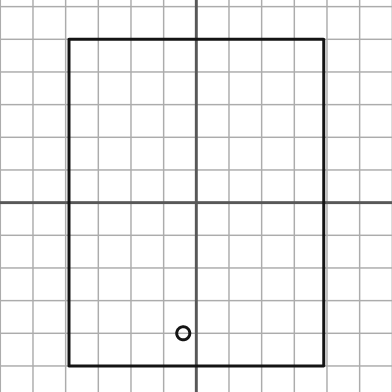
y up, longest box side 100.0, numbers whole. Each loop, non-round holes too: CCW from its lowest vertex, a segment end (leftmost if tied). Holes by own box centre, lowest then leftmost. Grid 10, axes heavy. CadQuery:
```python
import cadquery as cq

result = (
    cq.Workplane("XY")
    .moveTo(-39.0, -50.0)
    .lineTo(39.0, -50.0)
    .lineTo(39.0, 50.0)
    .lineTo(-39.0, 50.0)
    .close()
    .moveTo(-4.0, -40.0)
    .circle(2.0)
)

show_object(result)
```